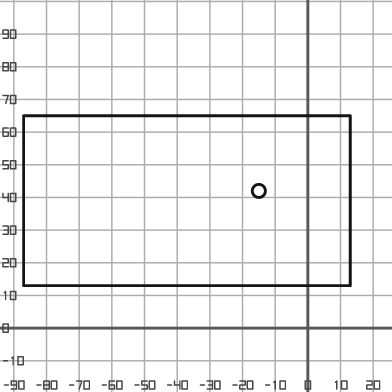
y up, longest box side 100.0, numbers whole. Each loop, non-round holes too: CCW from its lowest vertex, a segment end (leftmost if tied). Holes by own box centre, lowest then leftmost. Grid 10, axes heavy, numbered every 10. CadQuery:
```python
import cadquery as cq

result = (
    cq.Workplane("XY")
    .moveTo(-87.0, 13.0)
    .lineTo(13.0, 13.0)
    .lineTo(13.0, 65.0)
    .lineTo(-87.0, 65.0)
    .close()
    .moveTo(-15.0, 42.0)
    .circle(2.0)
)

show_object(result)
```